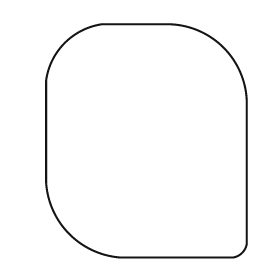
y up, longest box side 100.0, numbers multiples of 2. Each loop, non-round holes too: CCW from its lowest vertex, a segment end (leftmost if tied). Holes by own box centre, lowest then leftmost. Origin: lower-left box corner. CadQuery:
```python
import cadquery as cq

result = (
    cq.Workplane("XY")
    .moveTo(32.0, 0.0)
    .lineTo(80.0, 0.0)
    .threePointArc((84.0, 2.0), (86.0, 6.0))
    .lineTo(86.0, 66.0)
    .threePointArc((76.0, 90.0), (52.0, 100.0))
    .lineTo(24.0, 100.0)
    .threePointArc((8.0, 92.0), (0.0, 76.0))
    .lineTo(0.0, 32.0)
    .threePointArc((10.0, 10.0), (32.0, 0.0))
    .close()
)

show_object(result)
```